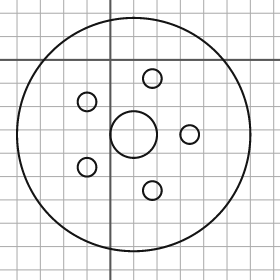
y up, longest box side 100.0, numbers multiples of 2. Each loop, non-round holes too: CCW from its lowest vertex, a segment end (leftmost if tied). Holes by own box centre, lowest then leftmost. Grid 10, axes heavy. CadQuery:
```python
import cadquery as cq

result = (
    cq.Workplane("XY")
    .moveTo(10.0, -32.0)
    .circle(50.0)
    .moveTo(18.0, -56.0)
    .circle(4.0)
    .moveTo(-10.0, -46.0)
    .circle(4.0)
    .moveTo(10.0, -32.0)
    .circle(10.0)
    .moveTo(34.0, -32.0)
    .circle(4.0)
    .moveTo(-10.0, -18.0)
    .circle(4.0)
    .moveTo(18.0, -8.0)
    .circle(4.0)
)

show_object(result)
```